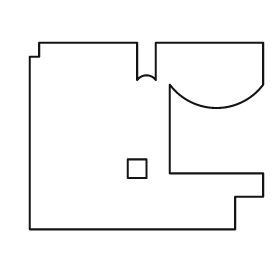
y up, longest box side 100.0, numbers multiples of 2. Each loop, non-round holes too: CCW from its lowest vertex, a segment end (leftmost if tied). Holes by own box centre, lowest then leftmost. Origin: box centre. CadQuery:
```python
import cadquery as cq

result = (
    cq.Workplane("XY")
    .moveTo(-50.0, -40.0)
    .lineTo(38.0, -40.0)
    .lineTo(38.0, -26.0)
    .lineTo(50.0, -26.0)
    .lineTo(50.0, -16.0)
    .lineTo(10.0, -16.0)
    .lineTo(10.0, 22.0)
    .threePointArc((30.0, 12.0), (50.0, 22.0))
    .lineTo(50.0, 40.0)
    .lineTo(4.0, 40.0)
    .lineTo(4.0, 24.0)
    .threePointArc((0.0, 26.0), (-4.0, 24.0))
    .lineTo(-4.0, 40.0)
    .lineTo(-46.0, 40.0)
    .lineTo(-46.0, 34.0)
    .lineTo(-50.0, 34.0)
    .close()
    .moveTo(-8.0, -18.0)
    .lineTo(0.0, -18.0)
    .lineTo(0.0, -10.0)
    .lineTo(-8.0, -10.0)
    .close()
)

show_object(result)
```